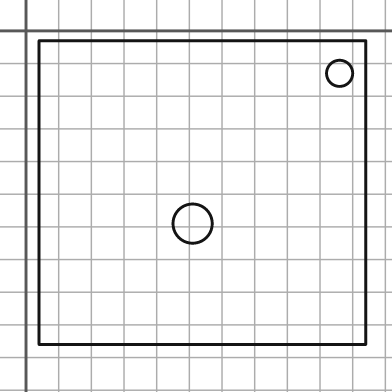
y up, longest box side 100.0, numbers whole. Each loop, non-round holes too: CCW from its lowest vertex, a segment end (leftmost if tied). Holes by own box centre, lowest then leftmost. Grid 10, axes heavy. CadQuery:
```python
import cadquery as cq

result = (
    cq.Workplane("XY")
    .moveTo(4.0, -96.0)
    .lineTo(104.0, -96.0)
    .lineTo(104.0, -3.0)
    .lineTo(4.0, -3.0)
    .close()
    .moveTo(51.0, -59.0)
    .circle(6.0)
    .moveTo(96.0, -13.0)
    .circle(4.0)
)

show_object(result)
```